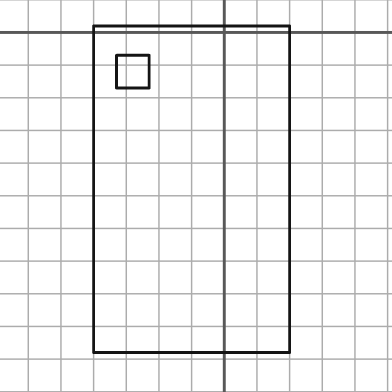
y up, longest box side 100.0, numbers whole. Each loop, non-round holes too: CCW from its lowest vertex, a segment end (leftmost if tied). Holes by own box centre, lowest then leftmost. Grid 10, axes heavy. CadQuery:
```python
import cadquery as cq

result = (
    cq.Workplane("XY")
    .moveTo(-40.0, -98.0)
    .lineTo(20.0, -98.0)
    .lineTo(20.0, 2.0)
    .lineTo(-40.0, 2.0)
    .close()
    .moveTo(-33.0, -17.0)
    .lineTo(-23.0, -17.0)
    .lineTo(-23.0, -7.0)
    .lineTo(-33.0, -7.0)
    .close()
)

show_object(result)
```